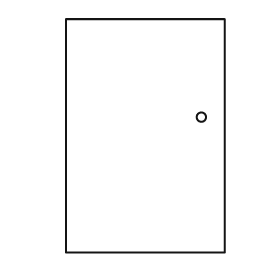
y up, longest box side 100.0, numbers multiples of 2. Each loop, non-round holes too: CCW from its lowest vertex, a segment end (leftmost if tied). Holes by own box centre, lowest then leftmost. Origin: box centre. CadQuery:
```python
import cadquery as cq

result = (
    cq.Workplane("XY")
    .moveTo(-34.0, -50.0)
    .lineTo(34.0, -50.0)
    .lineTo(34.0, 50.0)
    .lineTo(-34.0, 50.0)
    .close()
    .moveTo(24.0, 8.0)
    .circle(2.0)
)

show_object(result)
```